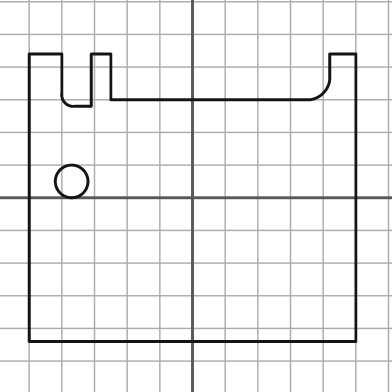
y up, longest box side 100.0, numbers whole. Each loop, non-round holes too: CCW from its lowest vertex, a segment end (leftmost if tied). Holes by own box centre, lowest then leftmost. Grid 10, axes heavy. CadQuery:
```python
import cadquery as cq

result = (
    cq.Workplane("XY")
    .moveTo(-50.0, -44.0)
    .lineTo(50.0, -44.0)
    .lineTo(50.0, 44.0)
    .lineTo(42.0, 44.0)
    .lineTo(42.0, 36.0)
    .threePointArc((40.0, 32.0), (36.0, 30.0))
    .lineTo(-25.0, 30.0)
    .lineTo(-25.0, 44.0)
    .lineTo(-31.0, 44.0)
    .lineTo(-31.0, 28.0)
    .lineTo(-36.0, 28.0)
    .threePointArc((-39.0, 29.0), (-40.0, 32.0))
    .lineTo(-40.0, 44.0)
    .lineTo(-50.0, 44.0)
    .close()
    .moveTo(-37.0, 5.0)
    .circle(5.0)
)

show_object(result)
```